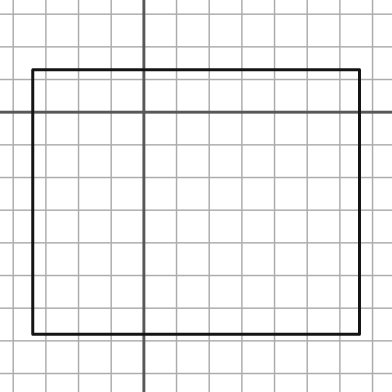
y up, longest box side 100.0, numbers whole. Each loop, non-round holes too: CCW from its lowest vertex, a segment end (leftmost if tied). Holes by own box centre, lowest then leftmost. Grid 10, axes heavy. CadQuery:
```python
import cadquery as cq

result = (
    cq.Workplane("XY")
    .moveTo(-34.0, -68.0)
    .lineTo(66.0, -68.0)
    .lineTo(66.0, 13.0)
    .lineTo(-34.0, 13.0)
    .close()
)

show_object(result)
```